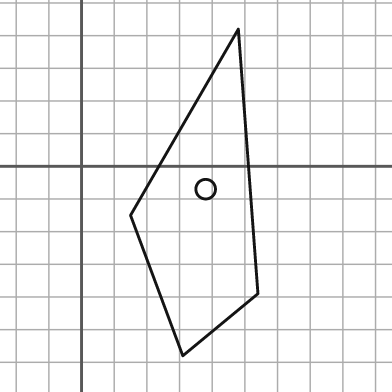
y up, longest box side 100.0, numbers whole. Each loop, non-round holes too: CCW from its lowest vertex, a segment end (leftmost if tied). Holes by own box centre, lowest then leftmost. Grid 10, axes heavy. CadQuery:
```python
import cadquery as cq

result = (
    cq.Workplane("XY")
    .moveTo(31.0, -58.0)
    .lineTo(54.0, -39.0)
    .lineTo(48.0, 42.0)
    .lineTo(15.0, -15.0)
    .close()
    .moveTo(38.0, -7.0)
    .circle(3.0)
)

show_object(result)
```